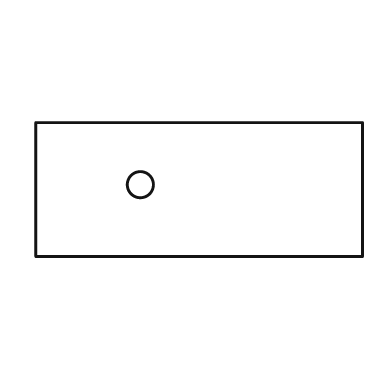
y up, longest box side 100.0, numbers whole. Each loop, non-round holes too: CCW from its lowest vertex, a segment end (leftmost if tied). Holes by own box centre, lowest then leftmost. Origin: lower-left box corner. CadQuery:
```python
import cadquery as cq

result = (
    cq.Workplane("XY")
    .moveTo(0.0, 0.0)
    .lineTo(100.0, 0.0)
    .lineTo(100.0, 41.0)
    .lineTo(0.0, 41.0)
    .close()
    .moveTo(32.0, 22.0)
    .circle(4.0)
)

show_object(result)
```